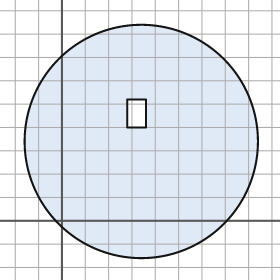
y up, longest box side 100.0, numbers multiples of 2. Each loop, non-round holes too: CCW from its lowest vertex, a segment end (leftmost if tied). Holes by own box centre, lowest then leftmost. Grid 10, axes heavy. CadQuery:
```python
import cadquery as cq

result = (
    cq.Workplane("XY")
    .moveTo(34.0, 34.0)
    .circle(50.0)
    .moveTo(28.0, 40.0)
    .lineTo(36.0, 40.0)
    .lineTo(36.0, 52.0)
    .lineTo(28.0, 52.0)
    .close()
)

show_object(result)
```